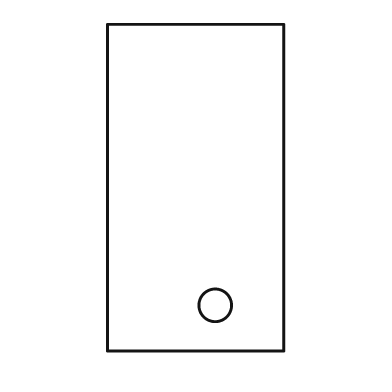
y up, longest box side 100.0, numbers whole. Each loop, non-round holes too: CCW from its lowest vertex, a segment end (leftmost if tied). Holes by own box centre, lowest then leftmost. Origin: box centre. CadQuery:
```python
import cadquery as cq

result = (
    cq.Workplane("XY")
    .moveTo(-27.0, -50.0)
    .lineTo(27.0, -50.0)
    .lineTo(27.0, 50.0)
    .lineTo(-27.0, 50.0)
    .close()
    .moveTo(6.0, -36.0)
    .circle(5.0)
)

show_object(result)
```